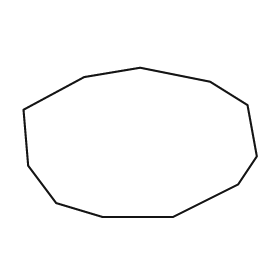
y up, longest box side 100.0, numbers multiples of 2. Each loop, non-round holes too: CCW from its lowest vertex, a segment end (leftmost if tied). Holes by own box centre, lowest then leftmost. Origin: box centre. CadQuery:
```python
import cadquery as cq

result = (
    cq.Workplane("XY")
    .moveTo(-16.0, -32.0)
    .lineTo(14.0, -32.0)
    .lineTo(42.0, -18.0)
    .lineTo(50.0, -6.0)
    .lineTo(46.0, 16.0)
    .lineTo(30.0, 26.0)
    .lineTo(0.0, 32.0)
    .lineTo(-24.0, 28.0)
    .lineTo(-50.0, 14.0)
    .lineTo(-48.0, -10.0)
    .lineTo(-36.0, -26.0)
    .close()
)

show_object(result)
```